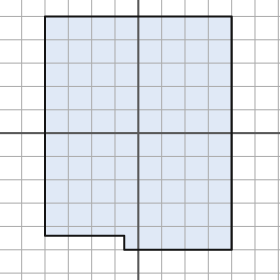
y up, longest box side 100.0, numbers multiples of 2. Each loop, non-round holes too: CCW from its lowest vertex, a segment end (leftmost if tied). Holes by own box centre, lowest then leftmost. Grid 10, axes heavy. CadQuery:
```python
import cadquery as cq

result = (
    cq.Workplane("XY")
    .moveTo(-6.0, -50.0)
    .lineTo(40.0, -50.0)
    .lineTo(40.0, 50.0)
    .lineTo(-40.0, 50.0)
    .lineTo(-40.0, -44.0)
    .lineTo(-6.0, -44.0)
    .close()
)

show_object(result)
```